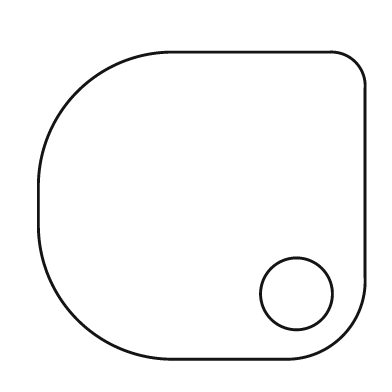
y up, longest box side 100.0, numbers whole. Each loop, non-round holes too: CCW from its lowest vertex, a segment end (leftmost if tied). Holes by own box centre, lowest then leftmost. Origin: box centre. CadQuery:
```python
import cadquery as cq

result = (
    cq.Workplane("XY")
    .moveTo(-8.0, -47.0)
    .lineTo(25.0, -47.0)
    .threePointArc((43.0, -40.0), (50.0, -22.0))
    .lineTo(50.0, 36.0)
    .threePointArc((47.0, 44.0), (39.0, 47.0))
    .lineTo(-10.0, 47.0)
    .threePointArc((-38.0, 35.0), (-50.0, 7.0))
    .lineTo(-50.0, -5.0)
    .threePointArc((-38.0, -35.0), (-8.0, -47.0))
    .close()
    .moveTo(29.0, -27.0)
    .circle(11.0)
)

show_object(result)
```